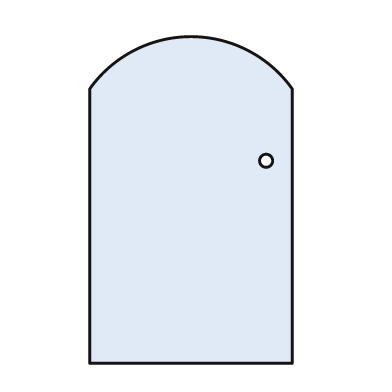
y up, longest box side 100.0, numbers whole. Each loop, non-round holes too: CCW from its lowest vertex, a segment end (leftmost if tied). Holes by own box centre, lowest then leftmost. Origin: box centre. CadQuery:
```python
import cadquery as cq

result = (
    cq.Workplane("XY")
    .moveTo(-31.0, -50.0)
    .lineTo(31.0, -50.0)
    .lineTo(31.0, 34.0)
    .threePointArc((0.0, 50.0), (-31.0, 34.0))
    .close()
    .moveTo(23.0, 12.0)
    .circle(2.0)
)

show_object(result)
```